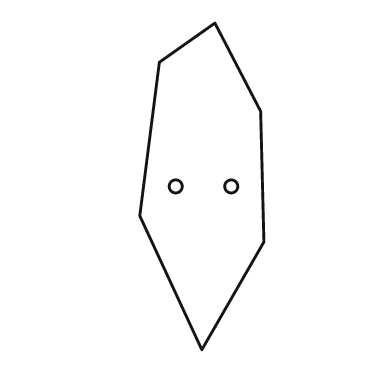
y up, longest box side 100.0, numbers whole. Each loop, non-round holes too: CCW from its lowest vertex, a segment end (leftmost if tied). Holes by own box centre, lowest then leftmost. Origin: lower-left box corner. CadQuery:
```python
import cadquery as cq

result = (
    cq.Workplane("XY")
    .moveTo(19.0, 0.0)
    .lineTo(38.0, 33.0)
    .lineTo(37.0, 73.0)
    .lineTo(23.0, 100.0)
    .lineTo(6.0, 88.0)
    .lineTo(0.0, 41.0)
    .close()
    .moveTo(11.0, 50.0)
    .circle(2.0)
    .moveTo(28.0, 50.0)
    .circle(2.0)
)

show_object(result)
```